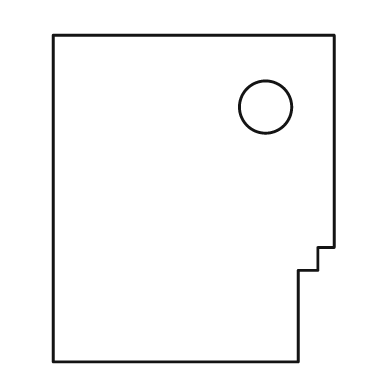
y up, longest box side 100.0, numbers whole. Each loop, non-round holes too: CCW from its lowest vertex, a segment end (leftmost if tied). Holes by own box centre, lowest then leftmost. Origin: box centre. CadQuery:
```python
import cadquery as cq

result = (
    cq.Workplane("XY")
    .moveTo(-43.0, -50.0)
    .lineTo(32.0, -50.0)
    .lineTo(32.0, -22.0)
    .lineTo(38.0, -22.0)
    .lineTo(38.0, -15.0)
    .lineTo(43.0, -15.0)
    .lineTo(43.0, 50.0)
    .lineTo(-43.0, 50.0)
    .close()
    .moveTo(22.0, 28.0)
    .circle(8.0)
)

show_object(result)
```